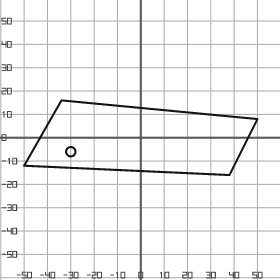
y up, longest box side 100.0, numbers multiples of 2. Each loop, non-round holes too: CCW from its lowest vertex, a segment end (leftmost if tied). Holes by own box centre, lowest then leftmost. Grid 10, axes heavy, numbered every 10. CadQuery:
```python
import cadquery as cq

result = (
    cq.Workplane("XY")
    .moveTo(38.0, -16.0)
    .lineTo(50.0, 8.0)
    .lineTo(-34.0, 16.0)
    .lineTo(-50.0, -12.0)
    .close()
    .moveTo(-30.0, -6.0)
    .circle(2.0)
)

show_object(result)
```